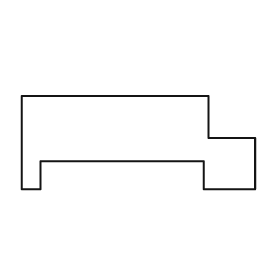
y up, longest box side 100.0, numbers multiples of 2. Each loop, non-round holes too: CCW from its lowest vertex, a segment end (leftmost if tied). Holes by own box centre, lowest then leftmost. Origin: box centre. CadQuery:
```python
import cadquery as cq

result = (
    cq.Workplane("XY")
    .moveTo(-50.0, -20.0)
    .lineTo(-42.0, -20.0)
    .lineTo(-42.0, -8.0)
    .lineTo(28.0, -8.0)
    .lineTo(28.0, -20.0)
    .lineTo(50.0, -20.0)
    .lineTo(50.0, 2.0)
    .lineTo(30.0, 2.0)
    .lineTo(30.0, 20.0)
    .lineTo(-50.0, 20.0)
    .close()
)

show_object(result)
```